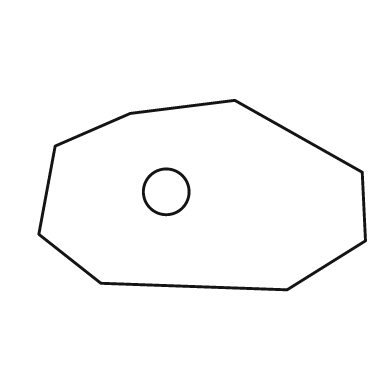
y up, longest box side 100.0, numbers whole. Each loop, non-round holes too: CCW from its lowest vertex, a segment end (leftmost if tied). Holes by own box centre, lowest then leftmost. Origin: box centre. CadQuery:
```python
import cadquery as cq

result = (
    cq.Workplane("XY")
    .moveTo(26.0, -29.0)
    .lineTo(50.0, -14.0)
    .lineTo(49.0, 7.0)
    .lineTo(10.0, 29.0)
    .lineTo(-22.0, 25.0)
    .lineTo(-45.0, 15.0)
    .lineTo(-50.0, -12.0)
    .lineTo(-31.0, -27.0)
    .close()
    .moveTo(-11.0, 1.0)
    .circle(7.0)
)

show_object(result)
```